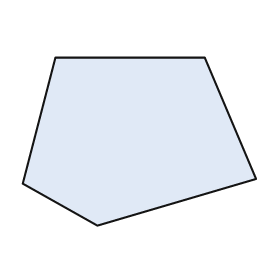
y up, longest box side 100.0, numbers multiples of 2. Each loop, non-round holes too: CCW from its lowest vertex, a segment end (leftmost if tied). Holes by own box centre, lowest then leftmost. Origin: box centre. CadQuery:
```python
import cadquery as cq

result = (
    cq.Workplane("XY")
    .moveTo(-18.0, -36.0)
    .lineTo(50.0, -16.0)
    .lineTo(28.0, 36.0)
    .lineTo(-36.0, 36.0)
    .lineTo(-50.0, -18.0)
    .close()
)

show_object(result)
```